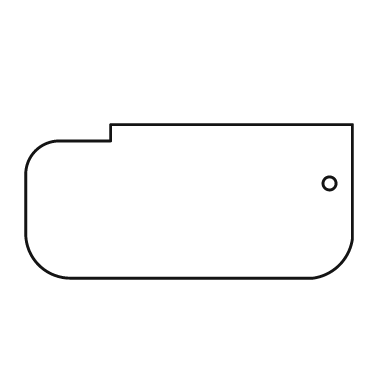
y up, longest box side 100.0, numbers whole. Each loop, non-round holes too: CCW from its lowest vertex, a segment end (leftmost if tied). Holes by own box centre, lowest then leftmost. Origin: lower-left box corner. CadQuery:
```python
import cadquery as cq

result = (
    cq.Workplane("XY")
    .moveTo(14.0, 0.0)
    .lineTo(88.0, 0.0)
    .threePointArc((96.0, 4.0), (100.0, 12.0))
    .lineTo(100.0, 47.0)
    .lineTo(26.0, 47.0)
    .lineTo(26.0, 42.0)
    .lineTo(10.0, 42.0)
    .threePointArc((3.0, 39.0), (0.0, 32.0))
    .lineTo(0.0, 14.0)
    .threePointArc((4.0, 4.0), (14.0, 0.0))
    .close()
    .moveTo(93.0, 29.0)
    .circle(2.0)
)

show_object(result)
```